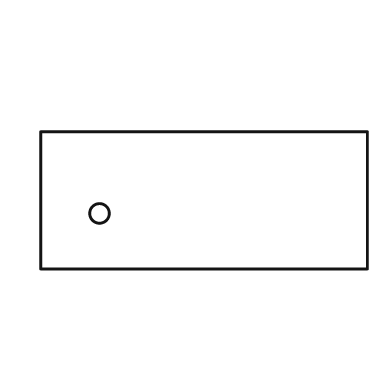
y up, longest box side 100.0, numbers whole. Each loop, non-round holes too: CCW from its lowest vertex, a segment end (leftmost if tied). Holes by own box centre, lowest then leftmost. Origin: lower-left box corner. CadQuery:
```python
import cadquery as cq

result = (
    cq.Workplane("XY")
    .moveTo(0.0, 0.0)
    .lineTo(100.0, 0.0)
    .lineTo(100.0, 42.0)
    .lineTo(0.0, 42.0)
    .close()
    .moveTo(18.0, 17.0)
    .circle(3.0)
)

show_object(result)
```